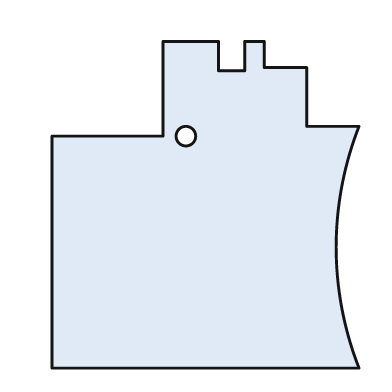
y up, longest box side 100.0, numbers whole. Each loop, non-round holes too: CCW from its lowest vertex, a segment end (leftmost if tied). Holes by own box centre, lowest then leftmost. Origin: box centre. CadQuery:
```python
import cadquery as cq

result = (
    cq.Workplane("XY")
    .moveTo(-47.0, -50.0)
    .lineTo(47.0, -50.0)
    .threePointArc((40.0, -13.0), (47.0, 24.0))
    .lineTo(31.0, 24.0)
    .lineTo(31.0, 42.0)
    .lineTo(18.0, 42.0)
    .lineTo(18.0, 50.0)
    .lineTo(12.0, 50.0)
    .lineTo(12.0, 41.0)
    .lineTo(4.0, 41.0)
    .lineTo(4.0, 50.0)
    .lineTo(-13.0, 50.0)
    .lineTo(-13.0, 21.0)
    .lineTo(-47.0, 21.0)
    .close()
    .moveTo(-6.0, 21.0)
    .circle(3.0)
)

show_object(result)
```